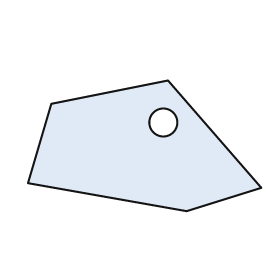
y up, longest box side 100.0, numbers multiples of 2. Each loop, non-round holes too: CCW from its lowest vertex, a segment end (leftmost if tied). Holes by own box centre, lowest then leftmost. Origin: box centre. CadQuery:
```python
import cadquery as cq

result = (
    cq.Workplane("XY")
    .moveTo(18.0, -28.0)
    .lineTo(50.0, -18.0)
    .lineTo(10.0, 28.0)
    .lineTo(-40.0, 18.0)
    .lineTo(-50.0, -16.0)
    .close()
    .moveTo(8.0, 10.0)
    .circle(6.0)
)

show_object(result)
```